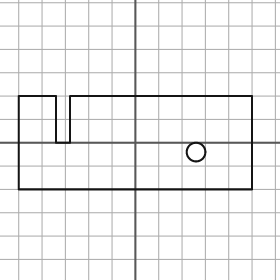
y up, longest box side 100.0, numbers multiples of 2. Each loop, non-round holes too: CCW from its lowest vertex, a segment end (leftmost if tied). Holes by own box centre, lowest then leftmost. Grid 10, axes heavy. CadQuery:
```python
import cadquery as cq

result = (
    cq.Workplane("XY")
    .moveTo(-50.0, -20.0)
    .lineTo(50.0, -20.0)
    .lineTo(50.0, 20.0)
    .lineTo(-28.0, 20.0)
    .lineTo(-28.0, 0.0)
    .lineTo(-34.0, 0.0)
    .lineTo(-34.0, 20.0)
    .lineTo(-50.0, 20.0)
    .close()
    .moveTo(26.0, -4.0)
    .circle(4.0)
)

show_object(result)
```